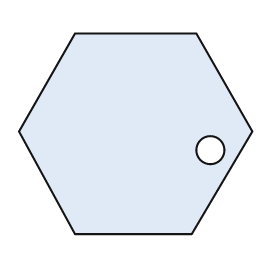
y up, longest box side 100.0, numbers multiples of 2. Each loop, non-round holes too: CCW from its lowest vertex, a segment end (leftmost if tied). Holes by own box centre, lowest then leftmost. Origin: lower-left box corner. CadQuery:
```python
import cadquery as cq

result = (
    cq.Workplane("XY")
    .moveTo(24.0, 0.0)
    .lineTo(74.0, 0.0)
    .lineTo(100.0, 44.0)
    .lineTo(76.0, 86.0)
    .lineTo(24.0, 86.0)
    .lineTo(0.0, 44.0)
    .close()
    .moveTo(82.0, 36.0)
    .circle(6.0)
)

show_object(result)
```